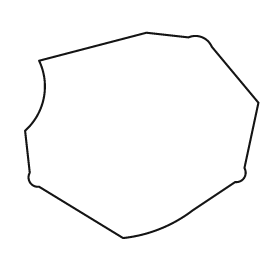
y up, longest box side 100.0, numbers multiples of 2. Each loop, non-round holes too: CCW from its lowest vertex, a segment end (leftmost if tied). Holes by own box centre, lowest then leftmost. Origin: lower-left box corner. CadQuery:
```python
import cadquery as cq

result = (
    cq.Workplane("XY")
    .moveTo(42.0, 0.0)
    .threePointArc((58.0, 4.0), (72.0, 12.0))
    .lineTo(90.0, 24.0)
    .threePointArc((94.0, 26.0), (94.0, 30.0))
    .lineTo(100.0, 58.0)
    .lineTo(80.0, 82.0)
    .threePointArc((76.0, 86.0), (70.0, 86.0))
    .lineTo(52.0, 88.0)
    .lineTo(6.0, 76.0)
    .threePointArc((8.0, 60.0), (0.0, 46.0))
    .lineTo(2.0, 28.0)
    .threePointArc((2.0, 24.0), (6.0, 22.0))
    .close()
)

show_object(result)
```